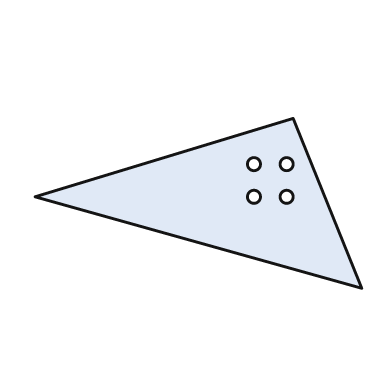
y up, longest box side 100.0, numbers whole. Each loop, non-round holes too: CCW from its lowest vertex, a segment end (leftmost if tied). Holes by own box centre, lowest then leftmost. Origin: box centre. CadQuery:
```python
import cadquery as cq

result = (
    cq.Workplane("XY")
    .moveTo(50.0, -26.0)
    .lineTo(29.0, 26.0)
    .lineTo(-50.0, 2.0)
    .close()
    .moveTo(17.0, 2.0)
    .circle(2.0)
    .moveTo(27.0, 2.0)
    .circle(2.0)
    .moveTo(17.0, 12.0)
    .circle(2.0)
    .moveTo(27.0, 12.0)
    .circle(2.0)
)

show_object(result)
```